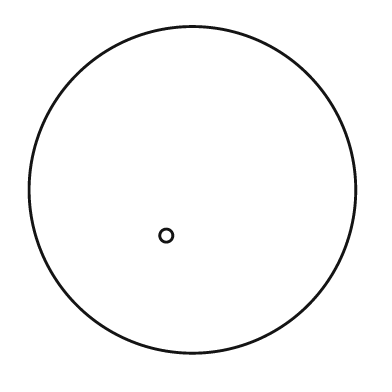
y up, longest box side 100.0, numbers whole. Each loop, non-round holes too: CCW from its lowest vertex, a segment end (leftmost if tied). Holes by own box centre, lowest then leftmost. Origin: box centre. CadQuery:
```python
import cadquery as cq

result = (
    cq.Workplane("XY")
    .moveTo(0.0, 0.0)
    .circle(50.0)
    .moveTo(-8.0, -14.0)
    .circle(2.0)
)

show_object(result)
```